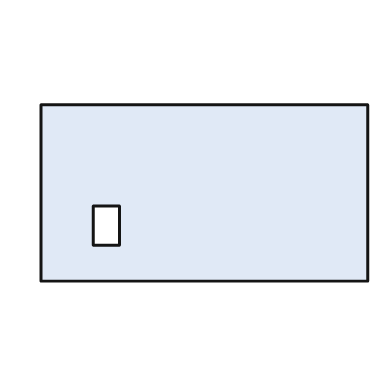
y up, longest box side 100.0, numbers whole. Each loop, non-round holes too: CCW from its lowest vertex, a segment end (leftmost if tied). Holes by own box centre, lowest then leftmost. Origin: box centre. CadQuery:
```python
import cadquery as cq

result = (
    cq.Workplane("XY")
    .moveTo(-50.0, -27.0)
    .lineTo(50.0, -27.0)
    .lineTo(50.0, 27.0)
    .lineTo(-50.0, 27.0)
    .close()
    .moveTo(-34.0, -16.0)
    .lineTo(-26.0, -16.0)
    .lineTo(-26.0, -4.0)
    .lineTo(-34.0, -4.0)
    .close()
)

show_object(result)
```